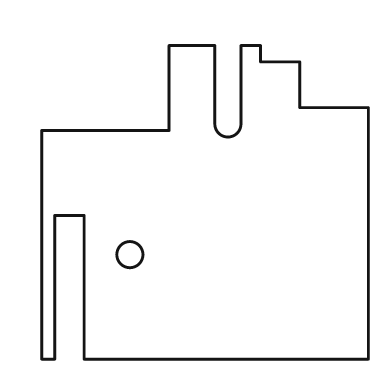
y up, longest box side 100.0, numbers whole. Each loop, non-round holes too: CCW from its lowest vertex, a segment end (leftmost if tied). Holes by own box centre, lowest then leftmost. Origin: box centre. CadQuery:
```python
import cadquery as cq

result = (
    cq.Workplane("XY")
    .moveTo(-50.0, -48.0)
    .lineTo(-46.0, -48.0)
    .lineTo(-46.0, -4.0)
    .lineTo(-37.0, -4.0)
    .lineTo(-37.0, -48.0)
    .lineTo(50.0, -48.0)
    .lineTo(50.0, 29.0)
    .lineTo(29.0, 29.0)
    .lineTo(29.0, 43.0)
    .lineTo(17.0, 43.0)
    .lineTo(17.0, 48.0)
    .lineTo(11.0, 48.0)
    .lineTo(11.0, 24.0)
    .threePointArc((7.0, 20.0), (3.0, 24.0))
    .lineTo(3.0, 48.0)
    .lineTo(-11.0, 48.0)
    .lineTo(-11.0, 22.0)
    .lineTo(-50.0, 22.0)
    .close()
    .moveTo(-23.0, -16.0)
    .circle(4.0)
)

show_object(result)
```